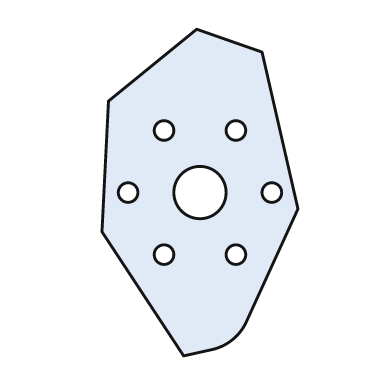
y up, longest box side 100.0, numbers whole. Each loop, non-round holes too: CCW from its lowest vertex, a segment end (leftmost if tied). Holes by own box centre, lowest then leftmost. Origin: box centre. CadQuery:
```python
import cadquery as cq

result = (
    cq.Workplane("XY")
    .moveTo(-5.0, -50.0)
    .lineTo(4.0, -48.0)
    .threePointArc((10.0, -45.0), (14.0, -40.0))
    .lineTo(30.0, -5.0)
    .lineTo(19.0, 43.0)
    .lineTo(-1.0, 50.0)
    .lineTo(-28.0, 28.0)
    .lineTo(-30.0, -12.0)
    .close()
    .moveTo(-11.0, -19.0)
    .circle(3.0)
    .moveTo(11.0, -19.0)
    .circle(3.0)
    .moveTo(-22.0, 0.0)
    .circle(3.0)
    .moveTo(0.0, 0.0)
    .circle(8.0)
    .moveTo(22.0, 0.0)
    .circle(3.0)
    .moveTo(-11.0, 19.0)
    .circle(3.0)
    .moveTo(11.0, 19.0)
    .circle(3.0)
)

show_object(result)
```